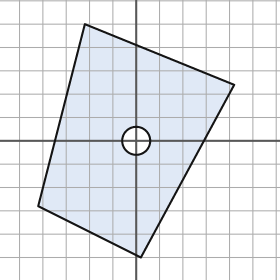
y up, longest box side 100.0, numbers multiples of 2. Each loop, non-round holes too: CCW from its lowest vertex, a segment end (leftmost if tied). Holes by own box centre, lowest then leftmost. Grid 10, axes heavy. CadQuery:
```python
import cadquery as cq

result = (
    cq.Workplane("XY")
    .moveTo(2.0, -50.0)
    .lineTo(42.0, 24.0)
    .lineTo(-22.0, 50.0)
    .lineTo(-42.0, -28.0)
    .close()
    .moveTo(0.0, 0.0)
    .circle(6.0)
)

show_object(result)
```